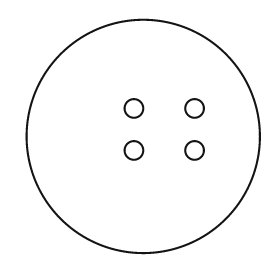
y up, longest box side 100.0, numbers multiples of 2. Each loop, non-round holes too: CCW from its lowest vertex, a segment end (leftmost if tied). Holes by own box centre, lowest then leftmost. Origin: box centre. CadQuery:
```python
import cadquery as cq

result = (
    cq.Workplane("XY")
    .moveTo(0.0, 0.0)
    .circle(50.0)
    .moveTo(-4.0, -6.0)
    .circle(4.0)
    .moveTo(22.0, -6.0)
    .circle(4.0)
    .moveTo(-4.0, 12.0)
    .circle(4.0)
    .moveTo(22.0, 12.0)
    .circle(4.0)
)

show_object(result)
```